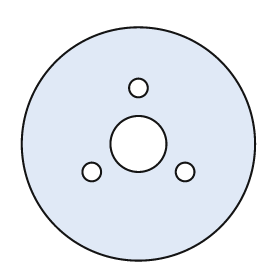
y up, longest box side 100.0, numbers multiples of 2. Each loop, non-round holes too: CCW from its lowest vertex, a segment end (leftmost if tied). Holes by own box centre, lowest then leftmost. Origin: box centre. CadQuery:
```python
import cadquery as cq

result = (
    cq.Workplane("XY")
    .moveTo(0.0, 0.0)
    .circle(50.0)
    .moveTo(-20.0, -12.0)
    .circle(4.0)
    .moveTo(20.0, -12.0)
    .circle(4.0)
    .moveTo(0.0, 0.0)
    .circle(12.0)
    .moveTo(0.0, 24.0)
    .circle(4.0)
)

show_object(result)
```